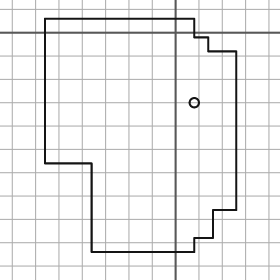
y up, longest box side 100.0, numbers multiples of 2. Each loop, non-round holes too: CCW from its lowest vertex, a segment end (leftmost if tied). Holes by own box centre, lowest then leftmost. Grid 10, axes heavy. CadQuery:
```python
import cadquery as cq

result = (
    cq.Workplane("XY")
    .moveTo(-36.0, -94.0)
    .lineTo(8.0, -94.0)
    .lineTo(8.0, -88.0)
    .lineTo(16.0, -88.0)
    .lineTo(16.0, -76.0)
    .lineTo(26.0, -76.0)
    .lineTo(26.0, -8.0)
    .lineTo(14.0, -8.0)
    .lineTo(14.0, -2.0)
    .lineTo(8.0, -2.0)
    .lineTo(8.0, 6.0)
    .lineTo(-56.0, 6.0)
    .lineTo(-56.0, -56.0)
    .lineTo(-36.0, -56.0)
    .close()
    .moveTo(8.0, -30.0)
    .circle(2.0)
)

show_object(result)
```